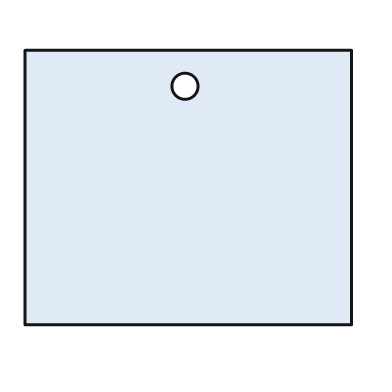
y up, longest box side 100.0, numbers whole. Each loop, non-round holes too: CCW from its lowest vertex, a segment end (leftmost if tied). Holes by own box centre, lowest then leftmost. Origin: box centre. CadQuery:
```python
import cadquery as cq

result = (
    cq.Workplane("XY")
    .moveTo(-50.0, -42.0)
    .lineTo(50.0, -42.0)
    .lineTo(50.0, 42.0)
    .lineTo(-50.0, 42.0)
    .close()
    .moveTo(-1.0, 31.0)
    .circle(4.0)
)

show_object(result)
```